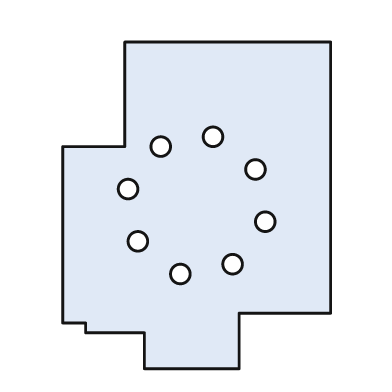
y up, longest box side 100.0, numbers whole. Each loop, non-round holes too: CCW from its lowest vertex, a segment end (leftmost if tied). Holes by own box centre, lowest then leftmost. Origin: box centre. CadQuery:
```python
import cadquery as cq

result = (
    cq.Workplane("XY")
    .moveTo(-16.0, -50.0)
    .lineTo(13.0, -50.0)
    .lineTo(13.0, -33.0)
    .lineTo(41.0, -33.0)
    .lineTo(41.0, 50.0)
    .lineTo(-22.0, 50.0)
    .lineTo(-22.0, 18.0)
    .lineTo(-41.0, 18.0)
    .lineTo(-41.0, -36.0)
    .lineTo(-34.0, -36.0)
    .lineTo(-34.0, -39.0)
    .lineTo(-16.0, -39.0)
    .close()
    .moveTo(-5.0, -21.0)
    .circle(3.0)
    .moveTo(11.0, -18.0)
    .circle(3.0)
    .moveTo(-18.0, -11.0)
    .circle(3.0)
    .moveTo(21.0, -5.0)
    .circle(3.0)
    .moveTo(-21.0, 5.0)
    .circle(3.0)
    .moveTo(18.0, 11.0)
    .circle(3.0)
    .moveTo(-11.0, 18.0)
    .circle(3.0)
    .moveTo(5.0, 21.0)
    .circle(3.0)
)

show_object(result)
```